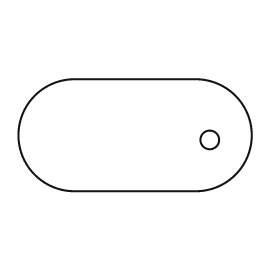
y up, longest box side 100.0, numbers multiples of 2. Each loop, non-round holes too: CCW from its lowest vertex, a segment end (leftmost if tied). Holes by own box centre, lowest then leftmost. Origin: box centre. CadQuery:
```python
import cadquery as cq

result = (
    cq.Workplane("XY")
    .moveTo(-26.0, -24.0)
    .lineTo(26.0, -24.0)
    .threePointArc((50.0, 0.0), (26.0, 24.0))
    .lineTo(-26.0, 24.0)
    .threePointArc((-50.0, 0.0), (-26.0, -24.0))
    .close()
    .moveTo(32.0, -2.0)
    .circle(4.0)
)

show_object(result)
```